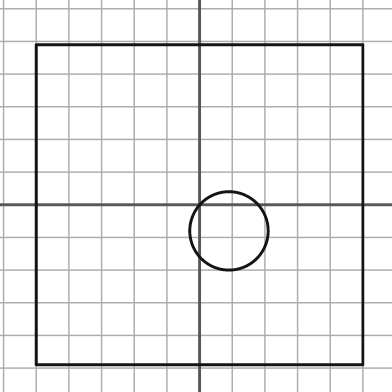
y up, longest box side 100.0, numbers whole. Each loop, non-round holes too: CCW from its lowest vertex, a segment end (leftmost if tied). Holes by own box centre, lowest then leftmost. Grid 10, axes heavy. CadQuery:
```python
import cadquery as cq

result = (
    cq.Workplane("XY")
    .moveTo(-50.0, -49.0)
    .lineTo(50.0, -49.0)
    .lineTo(50.0, 49.0)
    .lineTo(-50.0, 49.0)
    .close()
    .moveTo(9.0, -8.0)
    .circle(12.0)
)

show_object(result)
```